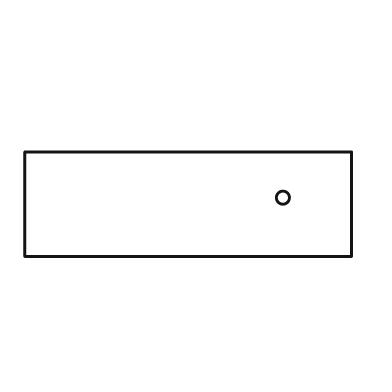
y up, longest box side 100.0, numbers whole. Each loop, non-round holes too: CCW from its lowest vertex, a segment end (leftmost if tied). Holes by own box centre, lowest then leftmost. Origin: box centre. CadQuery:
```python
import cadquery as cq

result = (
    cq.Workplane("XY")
    .moveTo(-50.0, -16.0)
    .lineTo(50.0, -16.0)
    .lineTo(50.0, 16.0)
    .lineTo(-50.0, 16.0)
    .close()
    .moveTo(29.0, 2.0)
    .circle(2.0)
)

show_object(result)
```